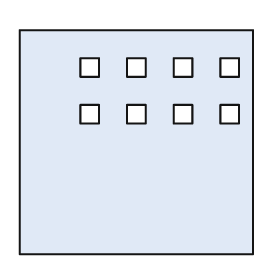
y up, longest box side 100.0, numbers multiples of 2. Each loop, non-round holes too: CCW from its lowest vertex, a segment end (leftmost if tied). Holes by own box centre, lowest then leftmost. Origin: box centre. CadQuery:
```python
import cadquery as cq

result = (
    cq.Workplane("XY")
    .moveTo(-50.0, -48.0)
    .lineTo(50.0, -48.0)
    .lineTo(50.0, 48.0)
    .lineTo(-50.0, 48.0)
    .close()
    .moveTo(-24.0, 8.0)
    .lineTo(-16.0, 8.0)
    .lineTo(-16.0, 16.0)
    .lineTo(-24.0, 16.0)
    .close()
    .moveTo(-4.0, 8.0)
    .lineTo(4.0, 8.0)
    .lineTo(4.0, 16.0)
    .lineTo(-4.0, 16.0)
    .close()
    .moveTo(16.0, 8.0)
    .lineTo(24.0, 8.0)
    .lineTo(24.0, 16.0)
    .lineTo(16.0, 16.0)
    .close()
    .moveTo(36.0, 8.0)
    .lineTo(44.0, 8.0)
    .lineTo(44.0, 16.0)
    .lineTo(36.0, 16.0)
    .close()
    .moveTo(-24.0, 28.0)
    .lineTo(-16.0, 28.0)
    .lineTo(-16.0, 36.0)
    .lineTo(-24.0, 36.0)
    .close()
    .moveTo(-4.0, 28.0)
    .lineTo(4.0, 28.0)
    .lineTo(4.0, 36.0)
    .lineTo(-4.0, 36.0)
    .close()
    .moveTo(16.0, 28.0)
    .lineTo(24.0, 28.0)
    .lineTo(24.0, 36.0)
    .lineTo(16.0, 36.0)
    .close()
    .moveTo(36.0, 28.0)
    .lineTo(44.0, 28.0)
    .lineTo(44.0, 36.0)
    .lineTo(36.0, 36.0)
    .close()
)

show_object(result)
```